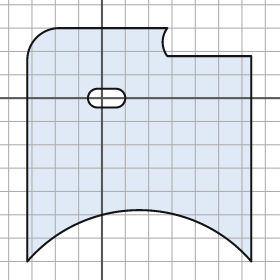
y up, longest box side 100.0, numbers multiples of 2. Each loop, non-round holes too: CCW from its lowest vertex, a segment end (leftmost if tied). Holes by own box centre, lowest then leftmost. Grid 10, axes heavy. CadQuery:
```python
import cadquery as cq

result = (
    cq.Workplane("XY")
    .moveTo(-32.0, -70.0)
    .threePointArc((16.0, -48.0), (64.0, -70.0))
    .lineTo(64.0, 18.0)
    .lineTo(28.0, 18.0)
    .threePointArc((26.0, 24.0), (28.0, 30.0))
    .lineTo(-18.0, 30.0)
    .threePointArc((-28.0, 26.0), (-32.0, 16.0))
    .close()
    .moveTo(-2.0, -4.0)
    .lineTo(6.0, -4.0)
    .threePointArc((10.0, 0.0), (6.0, 4.0))
    .lineTo(-2.0, 4.0)
    .threePointArc((-6.0, 0.0), (-2.0, -4.0))
    .close()
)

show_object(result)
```